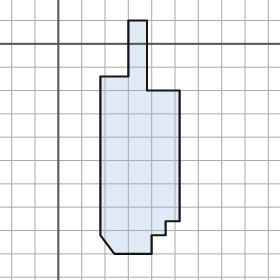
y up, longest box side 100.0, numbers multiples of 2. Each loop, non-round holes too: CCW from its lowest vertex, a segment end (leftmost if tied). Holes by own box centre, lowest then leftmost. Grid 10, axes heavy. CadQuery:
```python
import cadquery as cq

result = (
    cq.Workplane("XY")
    .moveTo(24.0, -90.0)
    .lineTo(40.0, -90.0)
    .lineTo(40.0, -82.0)
    .lineTo(46.0, -82.0)
    .lineTo(46.0, -76.0)
    .lineTo(52.0, -76.0)
    .lineTo(52.0, -20.0)
    .lineTo(38.0, -20.0)
    .lineTo(38.0, 10.0)
    .lineTo(30.0, 10.0)
    .lineTo(30.0, -14.0)
    .lineTo(18.0, -14.0)
    .lineTo(18.0, -82.0)
    .close()
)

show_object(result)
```